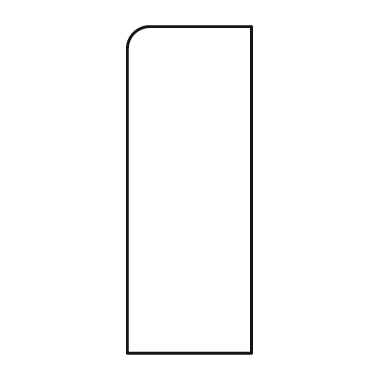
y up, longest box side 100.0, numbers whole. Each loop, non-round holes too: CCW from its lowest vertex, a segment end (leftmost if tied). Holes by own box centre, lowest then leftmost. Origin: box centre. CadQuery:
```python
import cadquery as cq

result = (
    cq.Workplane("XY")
    .moveTo(-19.0, -50.0)
    .lineTo(19.0, -50.0)
    .lineTo(19.0, 50.0)
    .lineTo(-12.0, 50.0)
    .threePointArc((-17.0, 48.0), (-19.0, 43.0))
    .close()
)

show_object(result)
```